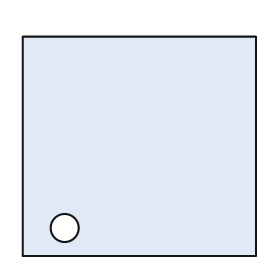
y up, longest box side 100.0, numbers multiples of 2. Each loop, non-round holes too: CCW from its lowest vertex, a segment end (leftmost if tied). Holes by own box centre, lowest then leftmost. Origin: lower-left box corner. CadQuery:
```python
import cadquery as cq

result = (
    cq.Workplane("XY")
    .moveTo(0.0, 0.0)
    .lineTo(100.0, 0.0)
    .lineTo(100.0, 94.0)
    .lineTo(0.0, 94.0)
    .close()
    .moveTo(18.0, 12.0)
    .circle(6.0)
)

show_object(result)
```